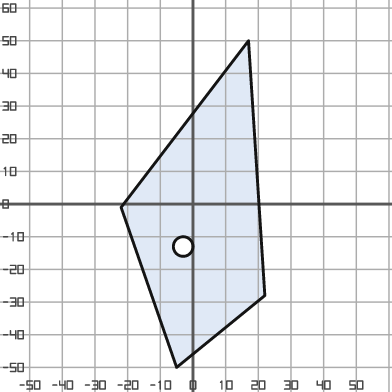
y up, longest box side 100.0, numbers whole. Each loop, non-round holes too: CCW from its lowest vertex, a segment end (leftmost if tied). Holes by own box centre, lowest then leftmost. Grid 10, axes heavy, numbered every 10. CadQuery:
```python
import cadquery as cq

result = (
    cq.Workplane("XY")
    .moveTo(-5.0, -50.0)
    .lineTo(22.0, -28.0)
    .lineTo(17.0, 50.0)
    .lineTo(-22.0, -1.0)
    .close()
    .moveTo(-3.0, -13.0)
    .circle(3.0)
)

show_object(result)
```